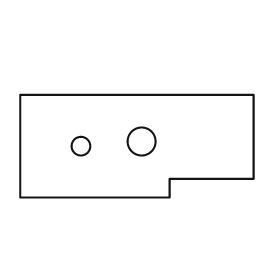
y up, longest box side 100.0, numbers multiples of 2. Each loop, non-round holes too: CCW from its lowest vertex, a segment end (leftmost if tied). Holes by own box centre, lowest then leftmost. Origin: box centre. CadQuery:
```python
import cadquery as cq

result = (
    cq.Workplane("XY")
    .moveTo(-50.0, -22.0)
    .lineTo(14.0, -22.0)
    .lineTo(14.0, -14.0)
    .lineTo(50.0, -14.0)
    .lineTo(50.0, 22.0)
    .lineTo(-50.0, 22.0)
    .close()
    .moveTo(-24.0, 0.0)
    .circle(4.0)
    .moveTo(2.0, 2.0)
    .circle(6.0)
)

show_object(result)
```